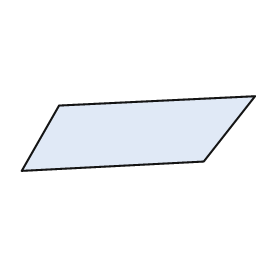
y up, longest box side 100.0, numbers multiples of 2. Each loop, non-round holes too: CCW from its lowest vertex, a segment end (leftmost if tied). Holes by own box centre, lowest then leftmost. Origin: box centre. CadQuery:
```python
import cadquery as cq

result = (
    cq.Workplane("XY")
    .moveTo(-50.0, -16.0)
    .lineTo(28.0, -12.0)
    .lineTo(50.0, 16.0)
    .lineTo(-34.0, 12.0)
    .close()
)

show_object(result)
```